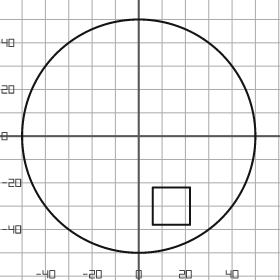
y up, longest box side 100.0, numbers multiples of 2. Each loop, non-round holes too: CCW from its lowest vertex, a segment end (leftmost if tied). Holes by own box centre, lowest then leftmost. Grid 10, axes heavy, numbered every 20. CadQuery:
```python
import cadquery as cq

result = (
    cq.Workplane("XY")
    .moveTo(0.0, 0.0)
    .circle(50.0)
    .moveTo(6.0, -38.0)
    .lineTo(22.0, -38.0)
    .lineTo(22.0, -22.0)
    .lineTo(6.0, -22.0)
    .close()
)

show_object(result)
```